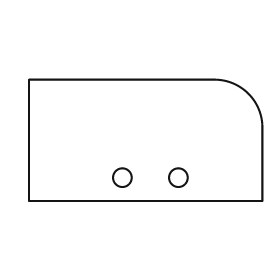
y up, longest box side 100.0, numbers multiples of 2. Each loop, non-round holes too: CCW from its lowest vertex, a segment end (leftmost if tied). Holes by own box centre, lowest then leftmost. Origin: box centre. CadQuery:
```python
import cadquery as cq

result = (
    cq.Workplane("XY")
    .moveTo(-50.0, -26.0)
    .lineTo(50.0, -26.0)
    .lineTo(50.0, 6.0)
    .threePointArc((44.0, 20.0), (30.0, 26.0))
    .lineTo(-50.0, 26.0)
    .close()
    .moveTo(-10.0, -16.0)
    .circle(4.0)
    .moveTo(14.0, -16.0)
    .circle(4.0)
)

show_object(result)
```